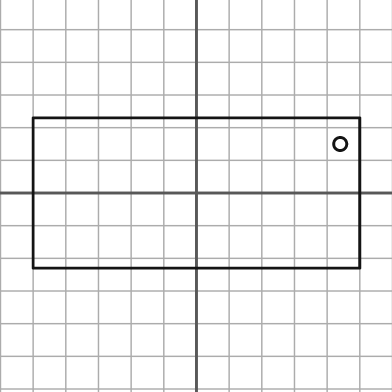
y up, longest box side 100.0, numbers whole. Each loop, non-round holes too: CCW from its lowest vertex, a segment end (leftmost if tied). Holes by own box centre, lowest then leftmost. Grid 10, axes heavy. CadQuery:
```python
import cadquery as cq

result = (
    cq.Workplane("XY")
    .moveTo(-50.0, -23.0)
    .lineTo(50.0, -23.0)
    .lineTo(50.0, 23.0)
    .lineTo(-50.0, 23.0)
    .close()
    .moveTo(44.0, 15.0)
    .circle(2.0)
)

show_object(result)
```